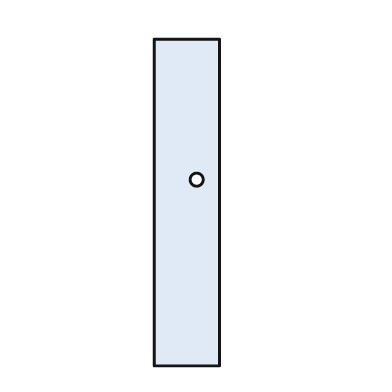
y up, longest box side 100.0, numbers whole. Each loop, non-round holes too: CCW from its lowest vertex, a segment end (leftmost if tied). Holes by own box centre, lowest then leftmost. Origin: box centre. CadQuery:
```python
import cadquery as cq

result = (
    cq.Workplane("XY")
    .moveTo(-10.0, -50.0)
    .lineTo(10.0, -50.0)
    .lineTo(10.0, 50.0)
    .lineTo(-10.0, 50.0)
    .close()
    .moveTo(3.0, 7.0)
    .circle(2.0)
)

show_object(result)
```